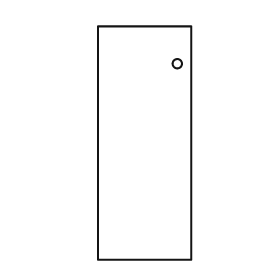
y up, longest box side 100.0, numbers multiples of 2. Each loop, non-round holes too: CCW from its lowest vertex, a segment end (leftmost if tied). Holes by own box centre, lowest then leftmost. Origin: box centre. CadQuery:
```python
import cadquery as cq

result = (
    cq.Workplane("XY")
    .moveTo(-20.0, -50.0)
    .lineTo(20.0, -50.0)
    .lineTo(20.0, 50.0)
    .lineTo(-20.0, 50.0)
    .close()
    .moveTo(14.0, 34.0)
    .circle(2.0)
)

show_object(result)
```